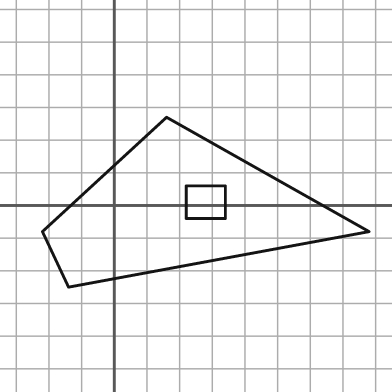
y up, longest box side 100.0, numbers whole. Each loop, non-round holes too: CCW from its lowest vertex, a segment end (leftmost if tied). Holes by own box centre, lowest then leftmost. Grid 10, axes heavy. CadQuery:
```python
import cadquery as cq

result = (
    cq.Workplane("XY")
    .moveTo(-14.0, -25.0)
    .lineTo(78.0, -8.0)
    .lineTo(16.0, 27.0)
    .lineTo(-22.0, -8.0)
    .close()
    .moveTo(22.0, -4.0)
    .lineTo(34.0, -4.0)
    .lineTo(34.0, 6.0)
    .lineTo(22.0, 6.0)
    .close()
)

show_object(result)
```